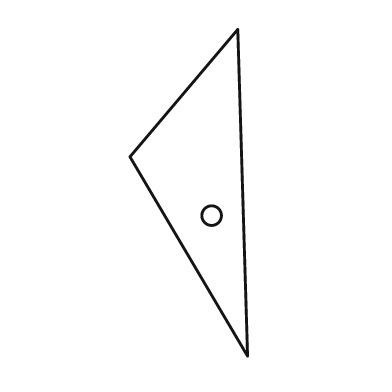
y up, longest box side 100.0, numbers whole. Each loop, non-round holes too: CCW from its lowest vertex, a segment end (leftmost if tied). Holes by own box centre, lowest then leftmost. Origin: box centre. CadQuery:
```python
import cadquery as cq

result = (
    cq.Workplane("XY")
    .moveTo(18.0, -50.0)
    .lineTo(15.0, 50.0)
    .lineTo(-18.0, 11.0)
    .close()
    .moveTo(7.0, -7.0)
    .circle(3.0)
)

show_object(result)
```